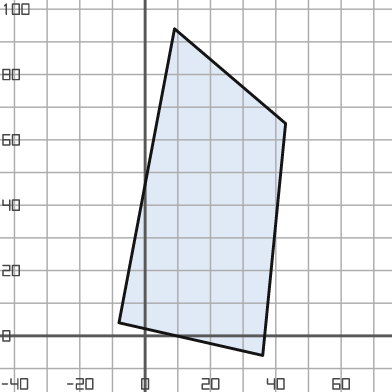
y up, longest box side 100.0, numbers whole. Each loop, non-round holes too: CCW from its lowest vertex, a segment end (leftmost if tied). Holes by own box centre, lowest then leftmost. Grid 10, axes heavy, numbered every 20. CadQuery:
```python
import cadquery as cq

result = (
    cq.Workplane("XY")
    .moveTo(36.0, -6.0)
    .lineTo(43.0, 65.0)
    .lineTo(9.0, 94.0)
    .lineTo(-8.0, 4.0)
    .close()
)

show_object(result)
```